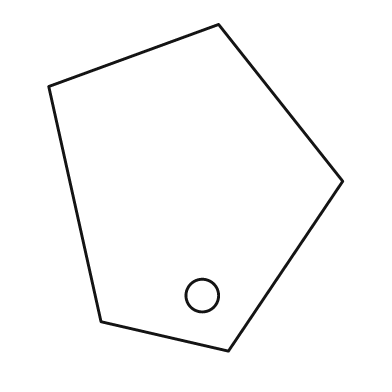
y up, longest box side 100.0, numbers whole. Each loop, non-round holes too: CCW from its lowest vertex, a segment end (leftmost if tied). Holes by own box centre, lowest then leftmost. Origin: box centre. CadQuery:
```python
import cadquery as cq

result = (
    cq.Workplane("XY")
    .moveTo(10.0, -50.0)
    .lineTo(45.0, 2.0)
    .lineTo(7.0, 50.0)
    .lineTo(-45.0, 31.0)
    .lineTo(-29.0, -41.0)
    .close()
    .moveTo(2.0, -33.0)
    .circle(5.0)
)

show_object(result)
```